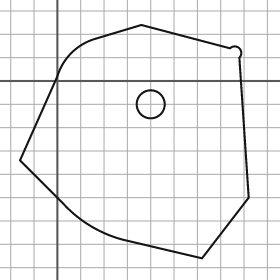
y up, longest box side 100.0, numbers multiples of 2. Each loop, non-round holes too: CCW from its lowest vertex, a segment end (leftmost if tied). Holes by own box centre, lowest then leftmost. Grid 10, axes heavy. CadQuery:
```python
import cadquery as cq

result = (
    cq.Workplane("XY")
    .moveTo(62.0, -76.0)
    .lineTo(82.0, -50.0)
    .lineTo(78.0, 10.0)
    .threePointArc((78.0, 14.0), (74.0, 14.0))
    .lineTo(36.0, 24.0)
    .lineTo(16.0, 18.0)
    .threePointArc((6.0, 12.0), (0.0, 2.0))
    .lineTo(-16.0, -34.0)
    .lineTo(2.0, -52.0)
    .threePointArc((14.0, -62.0), (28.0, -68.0))
    .close()
    .moveTo(40.0, -10.0)
    .circle(6.0)
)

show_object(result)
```